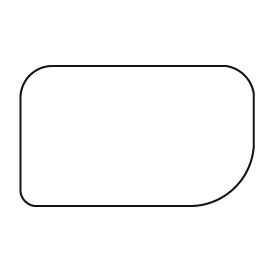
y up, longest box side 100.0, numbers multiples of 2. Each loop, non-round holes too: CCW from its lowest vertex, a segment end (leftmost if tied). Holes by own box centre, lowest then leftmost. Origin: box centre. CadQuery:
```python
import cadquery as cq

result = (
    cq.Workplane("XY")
    .moveTo(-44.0, -30.0)
    .lineTo(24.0, -30.0)
    .threePointArc((42.0, -22.0), (50.0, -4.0))
    .lineTo(50.0, 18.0)
    .threePointArc((46.0, 26.0), (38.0, 30.0))
    .lineTo(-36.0, 30.0)
    .threePointArc((-46.0, 26.0), (-50.0, 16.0))
    .lineTo(-50.0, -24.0)
    .threePointArc((-48.0, -28.0), (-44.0, -30.0))
    .close()
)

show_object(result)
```